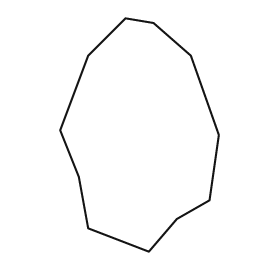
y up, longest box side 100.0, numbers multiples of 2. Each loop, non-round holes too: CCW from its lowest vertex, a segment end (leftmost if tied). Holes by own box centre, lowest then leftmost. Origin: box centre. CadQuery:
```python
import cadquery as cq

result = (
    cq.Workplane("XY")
    .moveTo(4.0, -50.0)
    .lineTo(16.0, -36.0)
    .lineTo(30.0, -28.0)
    .lineTo(34.0, 0.0)
    .lineTo(22.0, 34.0)
    .lineTo(6.0, 48.0)
    .lineTo(-6.0, 50.0)
    .lineTo(-22.0, 34.0)
    .lineTo(-34.0, 2.0)
    .lineTo(-26.0, -18.0)
    .lineTo(-22.0, -40.0)
    .close()
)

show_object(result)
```